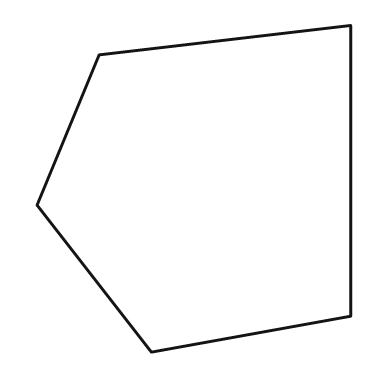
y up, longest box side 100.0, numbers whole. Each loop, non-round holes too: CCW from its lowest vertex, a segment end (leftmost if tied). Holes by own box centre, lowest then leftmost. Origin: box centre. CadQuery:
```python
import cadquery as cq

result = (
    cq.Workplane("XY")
    .moveTo(-13.0, -50.0)
    .lineTo(48.0, -39.0)
    .lineTo(48.0, 50.0)
    .lineTo(-29.0, 41.0)
    .lineTo(-48.0, -5.0)
    .close()
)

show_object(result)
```